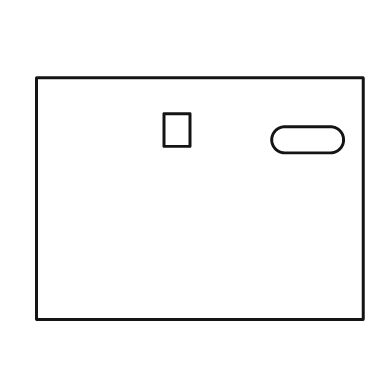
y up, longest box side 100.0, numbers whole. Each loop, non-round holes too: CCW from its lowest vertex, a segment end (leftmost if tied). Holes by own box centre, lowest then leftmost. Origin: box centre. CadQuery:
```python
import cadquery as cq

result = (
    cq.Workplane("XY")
    .moveTo(-50.0, -37.0)
    .lineTo(50.0, -37.0)
    .lineTo(50.0, 37.0)
    .lineTo(-50.0, 37.0)
    .close()
    .moveTo(26.0, 14.0)
    .lineTo(40.0, 14.0)
    .threePointArc((44.0, 18.0), (40.0, 22.0))
    .lineTo(26.0, 22.0)
    .threePointArc((22.0, 18.0), (26.0, 14.0))
    .close()
    .moveTo(-11.0, 16.0)
    .lineTo(-3.0, 16.0)
    .lineTo(-3.0, 26.0)
    .lineTo(-11.0, 26.0)
    .close()
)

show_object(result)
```